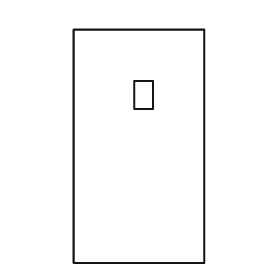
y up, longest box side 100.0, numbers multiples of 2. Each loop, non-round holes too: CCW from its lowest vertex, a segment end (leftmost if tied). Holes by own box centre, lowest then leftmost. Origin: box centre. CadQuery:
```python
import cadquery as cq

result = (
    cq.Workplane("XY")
    .moveTo(-28.0, -50.0)
    .lineTo(28.0, -50.0)
    .lineTo(28.0, 50.0)
    .lineTo(-28.0, 50.0)
    .close()
    .moveTo(-2.0, 16.0)
    .lineTo(6.0, 16.0)
    .lineTo(6.0, 28.0)
    .lineTo(-2.0, 28.0)
    .close()
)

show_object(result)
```